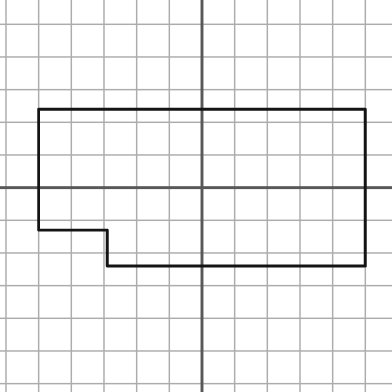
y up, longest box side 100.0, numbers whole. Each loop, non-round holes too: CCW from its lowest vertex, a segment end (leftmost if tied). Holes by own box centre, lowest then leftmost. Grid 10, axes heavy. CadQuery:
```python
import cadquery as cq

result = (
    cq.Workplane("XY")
    .moveTo(-29.0, -24.0)
    .lineTo(50.0, -24.0)
    .lineTo(50.0, 24.0)
    .lineTo(-50.0, 24.0)
    .lineTo(-50.0, -13.0)
    .lineTo(-29.0, -13.0)
    .close()
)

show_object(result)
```